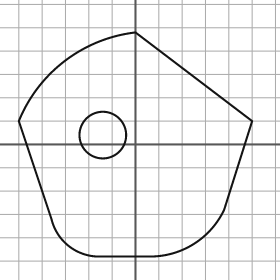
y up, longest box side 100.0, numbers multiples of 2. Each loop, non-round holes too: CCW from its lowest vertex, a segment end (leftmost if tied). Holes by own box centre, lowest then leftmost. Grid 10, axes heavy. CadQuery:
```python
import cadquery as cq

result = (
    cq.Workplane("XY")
    .moveTo(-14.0, -48.0)
    .lineTo(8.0, -48.0)
    .threePointArc((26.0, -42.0), (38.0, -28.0))
    .lineTo(50.0, 10.0)
    .lineTo(0.0, 48.0)
    .threePointArc((-30.0, 36.0), (-50.0, 10.0))
    .lineTo(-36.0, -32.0)
    .threePointArc((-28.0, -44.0), (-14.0, -48.0))
    .close()
    .moveTo(-14.0, 4.0)
    .circle(10.0)
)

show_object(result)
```